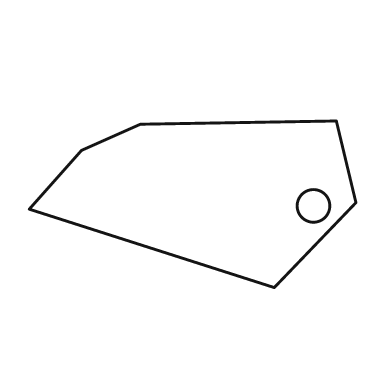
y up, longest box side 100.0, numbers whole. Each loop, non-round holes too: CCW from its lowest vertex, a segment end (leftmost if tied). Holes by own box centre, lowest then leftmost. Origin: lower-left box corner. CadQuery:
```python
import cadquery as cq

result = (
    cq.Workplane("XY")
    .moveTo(75.0, 0.0)
    .lineTo(100.0, 26.0)
    .lineTo(94.0, 51.0)
    .lineTo(34.0, 50.0)
    .lineTo(16.0, 42.0)
    .lineTo(0.0, 24.0)
    .close()
    .moveTo(87.0, 25.0)
    .circle(5.0)
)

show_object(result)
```